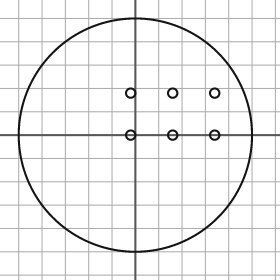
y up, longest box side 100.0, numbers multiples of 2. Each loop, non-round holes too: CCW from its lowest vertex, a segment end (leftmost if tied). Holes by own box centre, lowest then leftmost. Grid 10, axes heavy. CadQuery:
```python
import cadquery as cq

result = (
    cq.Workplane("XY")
    .moveTo(0.0, 0.0)
    .circle(50.0)
    .moveTo(-2.0, 0.0)
    .circle(2.0)
    .moveTo(16.0, 0.0)
    .circle(2.0)
    .moveTo(34.0, 0.0)
    .circle(2.0)
    .moveTo(-2.0, 18.0)
    .circle(2.0)
    .moveTo(16.0, 18.0)
    .circle(2.0)
    .moveTo(34.0, 18.0)
    .circle(2.0)
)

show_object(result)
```